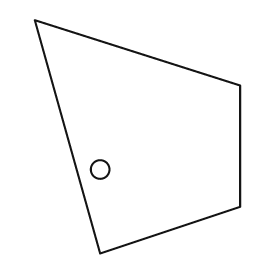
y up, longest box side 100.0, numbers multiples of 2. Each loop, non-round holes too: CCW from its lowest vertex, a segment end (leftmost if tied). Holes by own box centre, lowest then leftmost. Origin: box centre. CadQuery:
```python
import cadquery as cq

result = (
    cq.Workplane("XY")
    .moveTo(-16.0, -50.0)
    .lineTo(44.0, -30.0)
    .lineTo(44.0, 22.0)
    .lineTo(-44.0, 50.0)
    .close()
    .moveTo(-16.0, -14.0)
    .circle(4.0)
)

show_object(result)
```